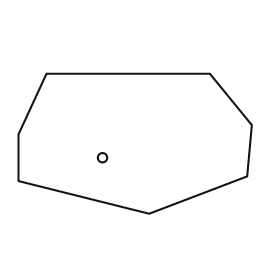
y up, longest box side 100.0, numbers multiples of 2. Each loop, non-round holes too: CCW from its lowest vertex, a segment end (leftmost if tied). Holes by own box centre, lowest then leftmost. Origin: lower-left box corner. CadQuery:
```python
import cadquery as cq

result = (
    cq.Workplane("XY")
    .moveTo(56.0, 0.0)
    .lineTo(98.0, 16.0)
    .lineTo(100.0, 38.0)
    .lineTo(82.0, 60.0)
    .lineTo(12.0, 60.0)
    .lineTo(0.0, 34.0)
    .lineTo(0.0, 14.0)
    .close()
    .moveTo(36.0, 24.0)
    .circle(2.0)
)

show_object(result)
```